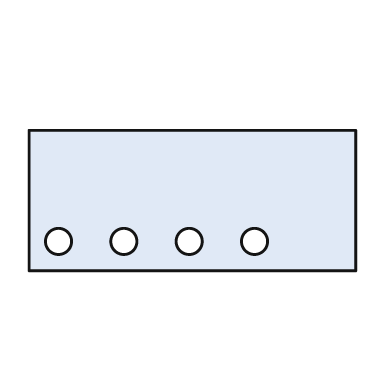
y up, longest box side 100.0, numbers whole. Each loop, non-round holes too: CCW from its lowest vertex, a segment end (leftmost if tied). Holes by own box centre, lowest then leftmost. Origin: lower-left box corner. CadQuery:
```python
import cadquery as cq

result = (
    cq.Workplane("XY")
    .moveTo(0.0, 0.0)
    .lineTo(100.0, 0.0)
    .lineTo(100.0, 43.0)
    .lineTo(0.0, 43.0)
    .close()
    .moveTo(9.0, 9.0)
    .circle(4.0)
    .moveTo(29.0, 9.0)
    .circle(4.0)
    .moveTo(49.0, 9.0)
    .circle(4.0)
    .moveTo(69.0, 9.0)
    .circle(4.0)
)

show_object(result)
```